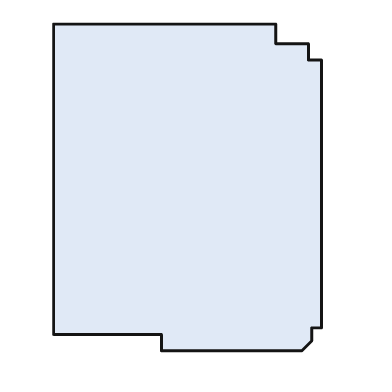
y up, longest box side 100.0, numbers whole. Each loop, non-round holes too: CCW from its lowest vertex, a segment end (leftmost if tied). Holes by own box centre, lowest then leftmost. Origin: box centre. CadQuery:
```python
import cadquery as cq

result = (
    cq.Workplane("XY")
    .moveTo(-8.0, -50.0)
    .lineTo(35.0, -50.0)
    .lineTo(38.0, -47.0)
    .lineTo(38.0, -43.0)
    .lineTo(41.0, -43.0)
    .lineTo(41.0, 39.0)
    .lineTo(37.0, 39.0)
    .lineTo(37.0, 44.0)
    .lineTo(27.0, 44.0)
    .lineTo(27.0, 50.0)
    .lineTo(-41.0, 50.0)
    .lineTo(-41.0, -45.0)
    .lineTo(-8.0, -45.0)
    .close()
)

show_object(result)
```